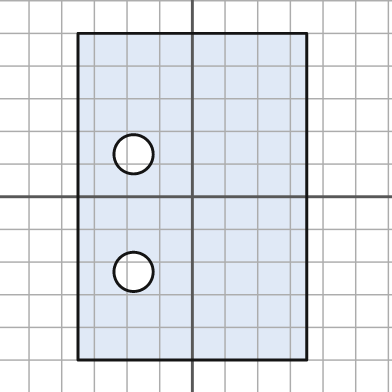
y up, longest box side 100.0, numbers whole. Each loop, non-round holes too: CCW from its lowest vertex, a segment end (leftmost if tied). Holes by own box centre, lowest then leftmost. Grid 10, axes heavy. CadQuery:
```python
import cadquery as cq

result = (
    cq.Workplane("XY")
    .moveTo(-35.0, -50.0)
    .lineTo(35.0, -50.0)
    .lineTo(35.0, 50.0)
    .lineTo(-35.0, 50.0)
    .close()
    .moveTo(-18.0, -23.0)
    .circle(6.0)
    .moveTo(-18.0, 13.0)
    .circle(6.0)
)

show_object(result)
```